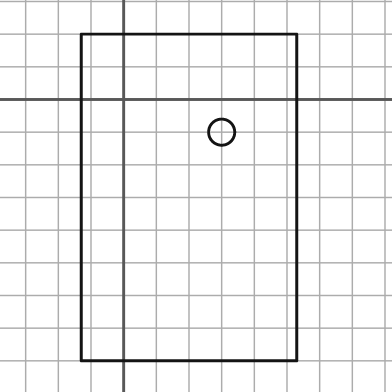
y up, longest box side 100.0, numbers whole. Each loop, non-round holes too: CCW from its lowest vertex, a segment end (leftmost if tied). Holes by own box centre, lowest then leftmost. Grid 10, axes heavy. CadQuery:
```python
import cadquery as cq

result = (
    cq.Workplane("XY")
    .moveTo(-13.0, -80.0)
    .lineTo(53.0, -80.0)
    .lineTo(53.0, 20.0)
    .lineTo(-13.0, 20.0)
    .close()
    .moveTo(30.0, -10.0)
    .circle(4.0)
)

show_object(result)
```